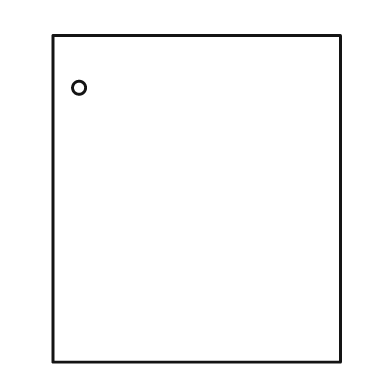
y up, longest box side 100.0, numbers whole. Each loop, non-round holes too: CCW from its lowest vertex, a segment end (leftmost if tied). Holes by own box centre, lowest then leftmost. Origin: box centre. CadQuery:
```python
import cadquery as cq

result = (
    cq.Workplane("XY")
    .moveTo(-44.0, -50.0)
    .lineTo(44.0, -50.0)
    .lineTo(44.0, 50.0)
    .lineTo(-44.0, 50.0)
    .close()
    .moveTo(-36.0, 34.0)
    .circle(2.0)
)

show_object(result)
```